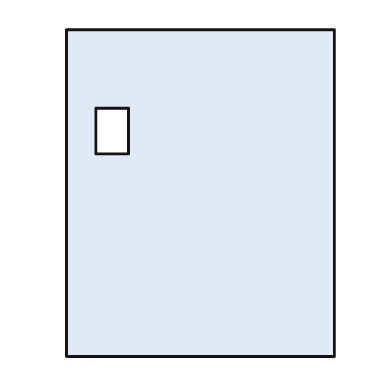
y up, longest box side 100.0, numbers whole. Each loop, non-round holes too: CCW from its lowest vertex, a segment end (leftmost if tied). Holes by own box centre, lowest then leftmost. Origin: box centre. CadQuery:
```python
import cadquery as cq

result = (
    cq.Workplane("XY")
    .moveTo(-41.0, -50.0)
    .lineTo(41.0, -50.0)
    .lineTo(41.0, 50.0)
    .lineTo(-41.0, 50.0)
    .close()
    .moveTo(-32.0, 12.0)
    .lineTo(-22.0, 12.0)
    .lineTo(-22.0, 26.0)
    .lineTo(-32.0, 26.0)
    .close()
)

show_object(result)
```